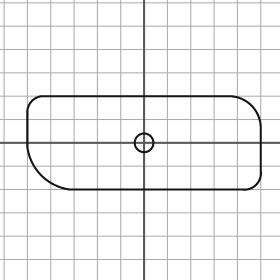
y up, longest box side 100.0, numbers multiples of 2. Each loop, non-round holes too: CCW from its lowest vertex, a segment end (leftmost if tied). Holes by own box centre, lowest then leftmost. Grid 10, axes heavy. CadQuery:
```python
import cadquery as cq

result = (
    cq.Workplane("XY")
    .moveTo(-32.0, -20.0)
    .lineTo(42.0, -20.0)
    .threePointArc((48.0, -18.0), (50.0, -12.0))
    .lineTo(50.0, 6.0)
    .threePointArc((46.0, 16.0), (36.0, 20.0))
    .lineTo(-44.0, 20.0)
    .threePointArc((-48.0, 18.0), (-50.0, 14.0))
    .lineTo(-50.0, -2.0)
    .threePointArc((-44.0, -14.0), (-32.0, -20.0))
    .close()
    .moveTo(0.0, 0.0)
    .circle(4.0)
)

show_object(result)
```